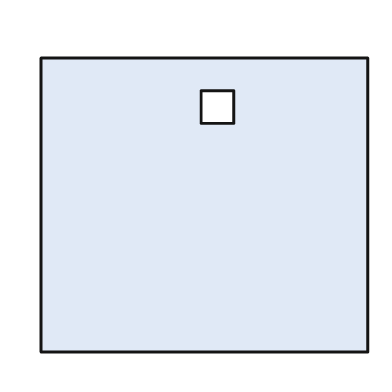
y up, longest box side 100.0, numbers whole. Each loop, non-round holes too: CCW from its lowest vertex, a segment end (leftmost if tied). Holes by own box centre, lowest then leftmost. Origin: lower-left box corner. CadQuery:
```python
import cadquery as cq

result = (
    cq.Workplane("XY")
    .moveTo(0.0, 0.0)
    .lineTo(100.0, 0.0)
    .lineTo(100.0, 90.0)
    .lineTo(0.0, 90.0)
    .close()
    .moveTo(49.0, 70.0)
    .lineTo(59.0, 70.0)
    .lineTo(59.0, 80.0)
    .lineTo(49.0, 80.0)
    .close()
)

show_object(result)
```